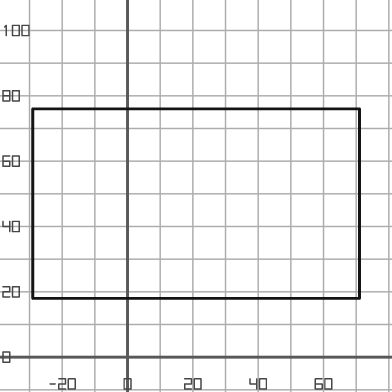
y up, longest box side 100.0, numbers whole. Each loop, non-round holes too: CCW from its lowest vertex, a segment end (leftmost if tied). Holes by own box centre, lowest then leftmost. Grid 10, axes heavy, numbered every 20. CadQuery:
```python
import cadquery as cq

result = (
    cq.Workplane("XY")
    .moveTo(-29.0, 18.0)
    .lineTo(71.0, 18.0)
    .lineTo(71.0, 76.0)
    .lineTo(-29.0, 76.0)
    .close()
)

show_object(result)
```